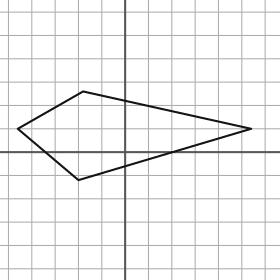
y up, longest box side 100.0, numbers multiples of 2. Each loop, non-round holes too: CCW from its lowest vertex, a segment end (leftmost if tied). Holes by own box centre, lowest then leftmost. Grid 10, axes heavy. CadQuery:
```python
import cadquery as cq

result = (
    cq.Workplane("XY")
    .moveTo(-20.0, -12.0)
    .lineTo(54.0, 10.0)
    .lineTo(-18.0, 26.0)
    .lineTo(-46.0, 10.0)
    .close()
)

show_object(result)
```